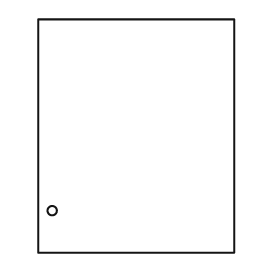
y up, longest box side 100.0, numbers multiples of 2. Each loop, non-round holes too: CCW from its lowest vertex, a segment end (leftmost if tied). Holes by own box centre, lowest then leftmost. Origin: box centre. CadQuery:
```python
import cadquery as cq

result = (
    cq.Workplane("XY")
    .moveTo(-42.0, -50.0)
    .lineTo(42.0, -50.0)
    .lineTo(42.0, 50.0)
    .lineTo(-42.0, 50.0)
    .close()
    .moveTo(-36.0, -32.0)
    .circle(2.0)
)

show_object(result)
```